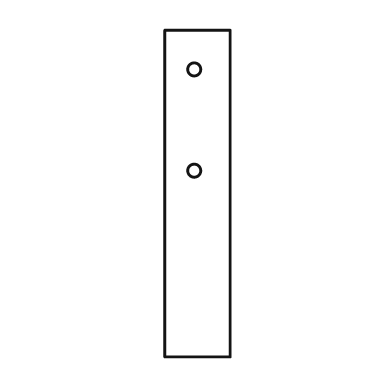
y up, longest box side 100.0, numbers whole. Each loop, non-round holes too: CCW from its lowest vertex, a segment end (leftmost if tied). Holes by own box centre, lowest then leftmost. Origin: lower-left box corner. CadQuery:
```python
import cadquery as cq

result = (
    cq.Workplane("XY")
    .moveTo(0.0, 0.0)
    .lineTo(20.0, 0.0)
    .lineTo(20.0, 100.0)
    .lineTo(0.0, 100.0)
    .close()
    .moveTo(9.0, 57.0)
    .circle(2.0)
    .moveTo(9.0, 88.0)
    .circle(2.0)
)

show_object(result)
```